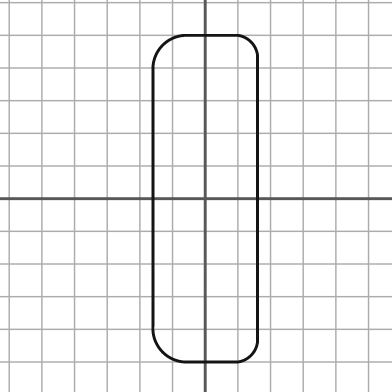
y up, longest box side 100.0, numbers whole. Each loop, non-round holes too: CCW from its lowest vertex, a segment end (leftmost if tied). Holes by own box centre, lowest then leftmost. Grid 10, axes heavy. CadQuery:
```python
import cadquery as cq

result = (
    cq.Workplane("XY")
    .moveTo(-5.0, -50.0)
    .lineTo(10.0, -50.0)
    .threePointArc((14.0, -48.0), (16.0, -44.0))
    .lineTo(16.0, 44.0)
    .threePointArc((14.0, 48.0), (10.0, 50.0))
    .lineTo(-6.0, 50.0)
    .threePointArc((-13.0, 47.0), (-16.0, 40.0))
    .lineTo(-16.0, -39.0)
    .threePointArc((-13.0, -47.0), (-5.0, -50.0))
    .close()
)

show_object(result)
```